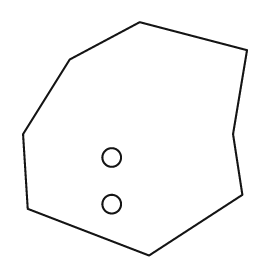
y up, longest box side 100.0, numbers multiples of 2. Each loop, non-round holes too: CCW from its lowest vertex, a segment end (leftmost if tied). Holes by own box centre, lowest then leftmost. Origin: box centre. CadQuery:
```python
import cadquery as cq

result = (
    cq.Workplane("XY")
    .moveTo(6.0, -50.0)
    .lineTo(46.0, -24.0)
    .lineTo(42.0, 2.0)
    .lineTo(48.0, 38.0)
    .lineTo(2.0, 50.0)
    .lineTo(-28.0, 34.0)
    .lineTo(-48.0, 2.0)
    .lineTo(-46.0, -30.0)
    .close()
    .moveTo(-10.0, -28.0)
    .circle(4.0)
    .moveTo(-10.0, -8.0)
    .circle(4.0)
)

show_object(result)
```